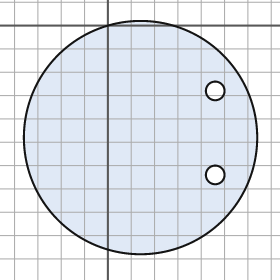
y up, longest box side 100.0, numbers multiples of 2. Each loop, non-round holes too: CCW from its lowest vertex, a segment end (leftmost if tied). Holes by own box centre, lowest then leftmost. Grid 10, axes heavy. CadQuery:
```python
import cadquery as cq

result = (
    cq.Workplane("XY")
    .moveTo(14.0, -48.0)
    .circle(50.0)
    .moveTo(46.0, -64.0)
    .circle(4.0)
    .moveTo(46.0, -28.0)
    .circle(4.0)
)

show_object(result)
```